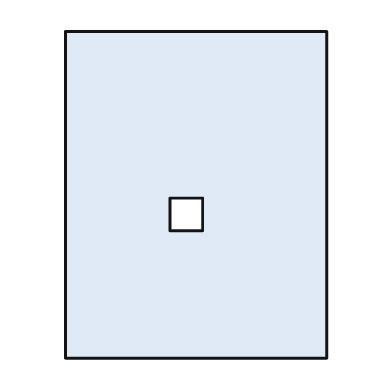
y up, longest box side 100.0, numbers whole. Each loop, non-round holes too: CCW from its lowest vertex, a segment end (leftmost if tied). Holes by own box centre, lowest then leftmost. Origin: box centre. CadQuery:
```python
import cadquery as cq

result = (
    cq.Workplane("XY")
    .moveTo(-40.0, -50.0)
    .lineTo(40.0, -50.0)
    .lineTo(40.0, 50.0)
    .lineTo(-40.0, 50.0)
    .close()
    .moveTo(-8.0, -11.0)
    .lineTo(2.0, -11.0)
    .lineTo(2.0, -1.0)
    .lineTo(-8.0, -1.0)
    .close()
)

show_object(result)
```